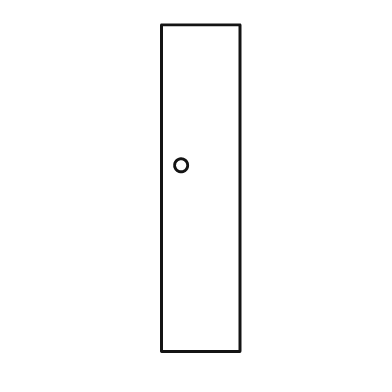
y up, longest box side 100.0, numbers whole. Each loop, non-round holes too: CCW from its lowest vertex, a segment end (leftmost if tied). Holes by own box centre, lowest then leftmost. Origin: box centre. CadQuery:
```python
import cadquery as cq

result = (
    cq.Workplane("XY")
    .moveTo(-12.0, -50.0)
    .lineTo(12.0, -50.0)
    .lineTo(12.0, 50.0)
    .lineTo(-12.0, 50.0)
    .close()
    .moveTo(-6.0, 7.0)
    .circle(2.0)
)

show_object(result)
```